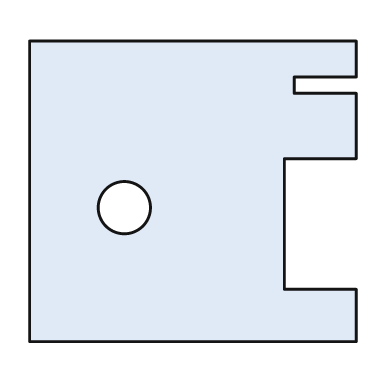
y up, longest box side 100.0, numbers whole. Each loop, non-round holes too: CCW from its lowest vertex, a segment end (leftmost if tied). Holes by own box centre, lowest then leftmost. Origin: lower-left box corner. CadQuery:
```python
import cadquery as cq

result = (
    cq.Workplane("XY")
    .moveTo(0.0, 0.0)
    .lineTo(100.0, 0.0)
    .lineTo(100.0, 16.0)
    .lineTo(78.0, 16.0)
    .lineTo(78.0, 56.0)
    .lineTo(100.0, 56.0)
    .lineTo(100.0, 76.0)
    .lineTo(81.0, 76.0)
    .lineTo(81.0, 81.0)
    .lineTo(100.0, 81.0)
    .lineTo(100.0, 92.0)
    .lineTo(0.0, 92.0)
    .close()
    .moveTo(29.0, 41.0)
    .circle(8.0)
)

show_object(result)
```